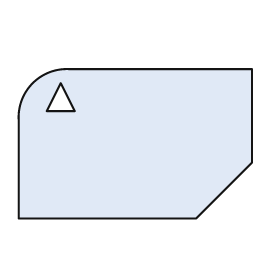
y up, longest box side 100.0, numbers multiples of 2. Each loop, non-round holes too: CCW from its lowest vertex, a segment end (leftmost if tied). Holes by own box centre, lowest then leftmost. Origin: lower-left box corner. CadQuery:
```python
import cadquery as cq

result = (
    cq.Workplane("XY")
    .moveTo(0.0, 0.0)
    .lineTo(76.0, 0.0)
    .lineTo(100.0, 24.0)
    .lineTo(100.0, 64.0)
    .lineTo(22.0, 64.0)
    .threePointArc((6.0, 58.0), (0.0, 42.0))
    .close()
    .moveTo(12.0, 46.0)
    .lineTo(24.0, 46.0)
    .lineTo(18.0, 58.0)
    .close()
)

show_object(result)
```